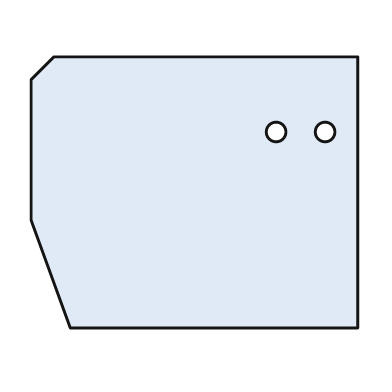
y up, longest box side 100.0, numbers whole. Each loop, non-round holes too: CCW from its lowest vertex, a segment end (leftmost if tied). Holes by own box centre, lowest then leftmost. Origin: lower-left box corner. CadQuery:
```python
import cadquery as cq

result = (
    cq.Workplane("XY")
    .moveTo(12.0, 0.0)
    .lineTo(100.0, 0.0)
    .lineTo(100.0, 83.0)
    .lineTo(7.0, 83.0)
    .lineTo(0.0, 76.0)
    .lineTo(0.0, 33.0)
    .close()
    .moveTo(75.0, 60.0)
    .circle(3.0)
    .moveTo(90.0, 60.0)
    .circle(3.0)
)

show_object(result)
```